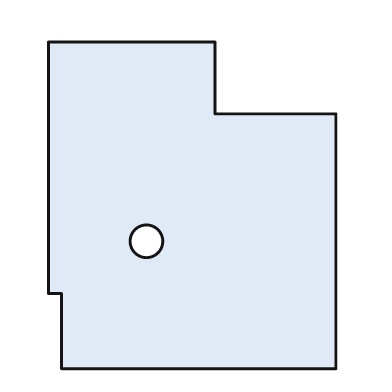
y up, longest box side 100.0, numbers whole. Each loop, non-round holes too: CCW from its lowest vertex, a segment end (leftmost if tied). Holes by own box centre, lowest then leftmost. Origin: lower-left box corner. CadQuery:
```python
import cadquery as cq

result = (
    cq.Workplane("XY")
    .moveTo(4.0, 0.0)
    .lineTo(88.0, 0.0)
    .lineTo(88.0, 78.0)
    .lineTo(51.0, 78.0)
    .lineTo(51.0, 100.0)
    .lineTo(0.0, 100.0)
    .lineTo(0.0, 23.0)
    .lineTo(4.0, 23.0)
    .close()
    .moveTo(30.0, 39.0)
    .circle(5.0)
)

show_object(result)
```